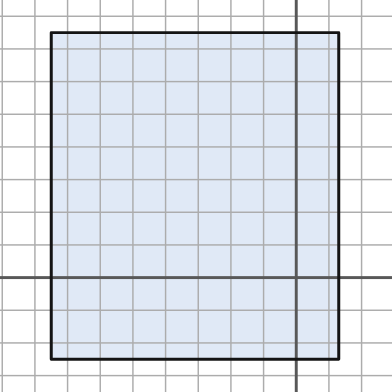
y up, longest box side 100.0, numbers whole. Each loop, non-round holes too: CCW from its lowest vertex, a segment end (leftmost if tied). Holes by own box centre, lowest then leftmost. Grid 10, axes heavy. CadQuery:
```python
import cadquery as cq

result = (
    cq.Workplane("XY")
    .moveTo(-75.0, -25.0)
    .lineTo(13.0, -25.0)
    .lineTo(13.0, 75.0)
    .lineTo(-75.0, 75.0)
    .close()
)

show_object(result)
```